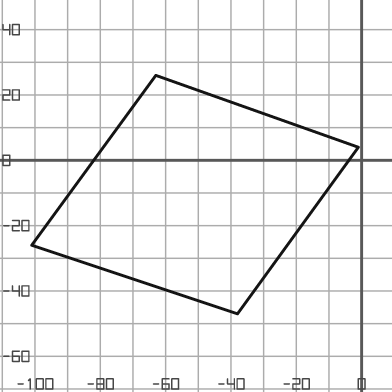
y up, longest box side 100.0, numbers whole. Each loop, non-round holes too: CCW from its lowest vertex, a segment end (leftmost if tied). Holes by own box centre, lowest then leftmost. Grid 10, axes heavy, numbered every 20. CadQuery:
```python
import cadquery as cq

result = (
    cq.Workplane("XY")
    .moveTo(-38.0, -47.0)
    .lineTo(-1.0, 4.0)
    .lineTo(-63.0, 26.0)
    .lineTo(-101.0, -26.0)
    .close()
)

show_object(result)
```